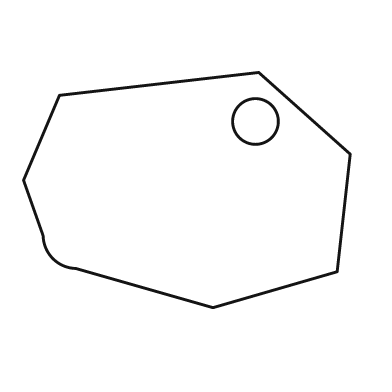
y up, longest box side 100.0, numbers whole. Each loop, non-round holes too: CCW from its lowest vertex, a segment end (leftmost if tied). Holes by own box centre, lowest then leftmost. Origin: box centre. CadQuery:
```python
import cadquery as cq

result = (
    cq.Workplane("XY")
    .moveTo(8.0, -36.0)
    .lineTo(46.0, -25.0)
    .lineTo(50.0, 11.0)
    .lineTo(22.0, 36.0)
    .lineTo(-39.0, 29.0)
    .lineTo(-50.0, 3.0)
    .lineTo(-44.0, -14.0)
    .threePointArc((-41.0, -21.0), (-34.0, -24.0))
    .close()
    .moveTo(21.0, 21.0)
    .circle(7.0)
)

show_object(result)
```